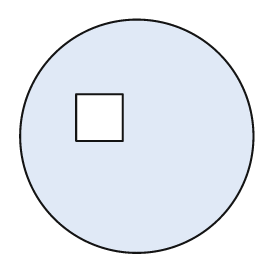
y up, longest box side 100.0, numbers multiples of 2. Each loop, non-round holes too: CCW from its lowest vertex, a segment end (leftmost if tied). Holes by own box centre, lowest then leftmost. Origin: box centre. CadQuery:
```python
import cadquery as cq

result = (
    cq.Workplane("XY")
    .moveTo(0.0, 0.0)
    .circle(50.0)
    .moveTo(-26.0, -2.0)
    .lineTo(-6.0, -2.0)
    .lineTo(-6.0, 18.0)
    .lineTo(-26.0, 18.0)
    .close()
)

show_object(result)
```